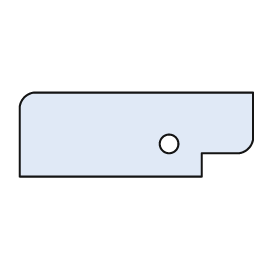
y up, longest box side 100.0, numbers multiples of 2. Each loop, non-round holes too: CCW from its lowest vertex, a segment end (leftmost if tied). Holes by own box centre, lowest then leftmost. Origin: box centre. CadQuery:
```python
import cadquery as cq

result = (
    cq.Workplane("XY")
    .moveTo(-50.0, -18.0)
    .lineTo(28.0, -18.0)
    .lineTo(28.0, -8.0)
    .lineTo(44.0, -8.0)
    .threePointArc((48.0, -6.0), (50.0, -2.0))
    .lineTo(50.0, 18.0)
    .lineTo(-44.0, 18.0)
    .threePointArc((-48.0, 16.0), (-50.0, 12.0))
    .close()
    .moveTo(14.0, -4.0)
    .circle(4.0)
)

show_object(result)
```